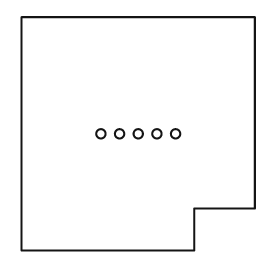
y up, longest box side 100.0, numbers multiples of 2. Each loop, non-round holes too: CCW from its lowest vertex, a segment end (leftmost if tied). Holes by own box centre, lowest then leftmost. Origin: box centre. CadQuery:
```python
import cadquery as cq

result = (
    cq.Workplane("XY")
    .moveTo(-50.0, -50.0)
    .lineTo(24.0, -50.0)
    .lineTo(24.0, -32.0)
    .lineTo(50.0, -32.0)
    .lineTo(50.0, 50.0)
    .lineTo(-50.0, 50.0)
    .close()
    .moveTo(-16.0, 0.0)
    .circle(2.0)
    .moveTo(-8.0, 0.0)
    .circle(2.0)
    .moveTo(0.0, 0.0)
    .circle(2.0)
    .moveTo(8.0, 0.0)
    .circle(2.0)
    .moveTo(16.0, 0.0)
    .circle(2.0)
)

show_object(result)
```